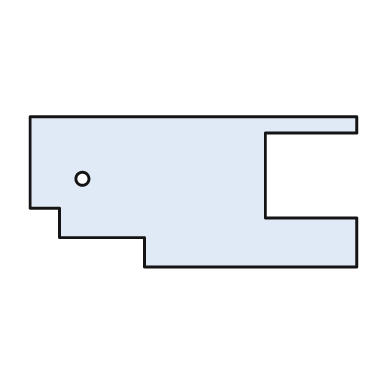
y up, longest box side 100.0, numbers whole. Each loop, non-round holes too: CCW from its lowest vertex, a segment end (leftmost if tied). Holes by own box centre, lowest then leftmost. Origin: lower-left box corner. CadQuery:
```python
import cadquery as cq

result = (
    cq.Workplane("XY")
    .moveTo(35.0, 0.0)
    .lineTo(100.0, 0.0)
    .lineTo(100.0, 15.0)
    .lineTo(72.0, 15.0)
    .lineTo(72.0, 41.0)
    .lineTo(100.0, 41.0)
    .lineTo(100.0, 46.0)
    .lineTo(0.0, 46.0)
    .lineTo(0.0, 18.0)
    .lineTo(9.0, 18.0)
    .lineTo(9.0, 9.0)
    .lineTo(35.0, 9.0)
    .close()
    .moveTo(16.0, 27.0)
    .circle(2.0)
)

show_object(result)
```